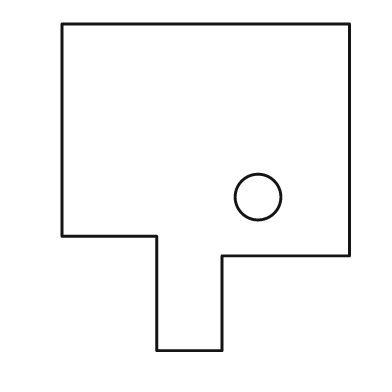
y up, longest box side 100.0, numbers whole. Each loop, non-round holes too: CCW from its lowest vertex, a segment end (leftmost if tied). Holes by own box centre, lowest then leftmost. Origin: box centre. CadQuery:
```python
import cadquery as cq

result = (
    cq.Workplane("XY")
    .moveTo(-15.0, -50.0)
    .lineTo(5.0, -50.0)
    .lineTo(5.0, -21.0)
    .lineTo(44.0, -21.0)
    .lineTo(44.0, 50.0)
    .lineTo(-44.0, 50.0)
    .lineTo(-44.0, -15.0)
    .lineTo(-15.0, -15.0)
    .close()
    .moveTo(16.0, -3.0)
    .circle(7.0)
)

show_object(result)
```